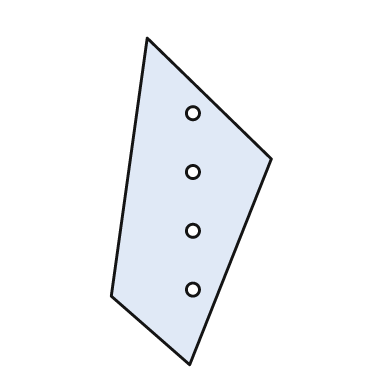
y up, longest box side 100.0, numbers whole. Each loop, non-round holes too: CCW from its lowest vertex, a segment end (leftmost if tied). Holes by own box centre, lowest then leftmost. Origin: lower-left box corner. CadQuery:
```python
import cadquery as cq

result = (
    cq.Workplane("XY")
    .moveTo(24.0, 0.0)
    .lineTo(49.0, 63.0)
    .lineTo(11.0, 100.0)
    .lineTo(0.0, 21.0)
    .close()
    .moveTo(25.0, 23.0)
    .circle(2.0)
    .moveTo(25.0, 41.0)
    .circle(2.0)
    .moveTo(25.0, 59.0)
    .circle(2.0)
    .moveTo(25.0, 77.0)
    .circle(2.0)
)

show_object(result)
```